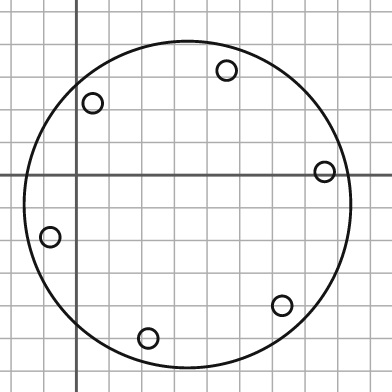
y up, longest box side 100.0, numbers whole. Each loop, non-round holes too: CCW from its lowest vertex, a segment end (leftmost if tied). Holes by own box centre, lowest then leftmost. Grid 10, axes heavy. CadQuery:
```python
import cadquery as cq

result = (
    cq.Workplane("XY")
    .moveTo(34.0, -9.0)
    .circle(50.0)
    .moveTo(22.0, -50.0)
    .circle(3.0)
    .moveTo(63.0, -40.0)
    .circle(3.0)
    .moveTo(-8.0, -19.0)
    .circle(3.0)
    .moveTo(76.0, 1.0)
    .circle(3.0)
    .moveTo(5.0, 22.0)
    .circle(3.0)
    .moveTo(46.0, 32.0)
    .circle(3.0)
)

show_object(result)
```